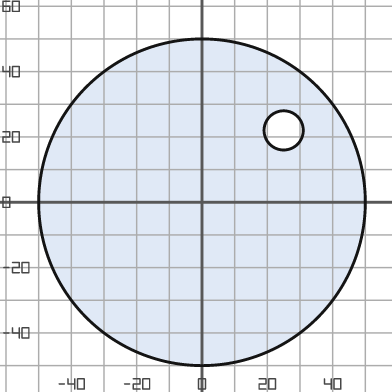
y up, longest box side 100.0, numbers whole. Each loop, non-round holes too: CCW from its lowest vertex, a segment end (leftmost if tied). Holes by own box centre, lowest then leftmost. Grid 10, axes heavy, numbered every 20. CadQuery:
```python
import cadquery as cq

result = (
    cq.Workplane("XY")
    .moveTo(0.0, 0.0)
    .circle(50.0)
    .moveTo(25.0, 22.0)
    .circle(6.0)
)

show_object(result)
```